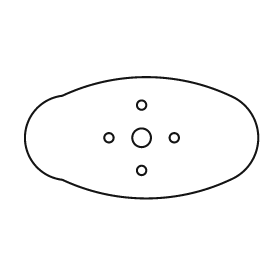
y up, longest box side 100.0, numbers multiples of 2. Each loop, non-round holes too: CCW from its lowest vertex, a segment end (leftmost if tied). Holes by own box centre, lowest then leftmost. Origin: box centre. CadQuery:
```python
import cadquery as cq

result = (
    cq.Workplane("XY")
    .moveTo(-34.0, -18.0)
    .threePointArc((2.0, -26.0), (38.0, -18.0))
    .threePointArc((50.0, 0.0), (38.0, 18.0))
    .threePointArc((2.0, 26.0), (-34.0, 18.0))
    .threePointArc((-50.0, 0.0), (-34.0, -18.0))
    .close()
    .moveTo(0.0, -14.0)
    .circle(2.0)
    .moveTo(-14.0, 0.0)
    .circle(2.0)
    .moveTo(0.0, 0.0)
    .circle(4.0)
    .moveTo(14.0, 0.0)
    .circle(2.0)
    .moveTo(0.0, 14.0)
    .circle(2.0)
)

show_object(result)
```